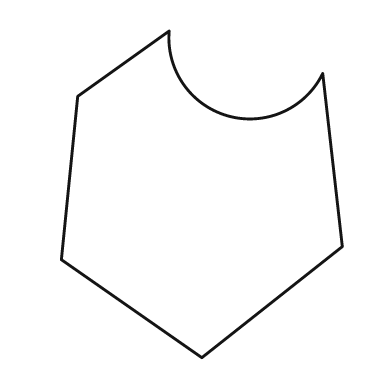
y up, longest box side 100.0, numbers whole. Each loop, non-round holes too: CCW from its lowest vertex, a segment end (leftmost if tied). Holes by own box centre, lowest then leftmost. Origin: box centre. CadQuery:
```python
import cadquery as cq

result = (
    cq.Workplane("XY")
    .moveTo(0.0, -50.0)
    .lineTo(43.0, -16.0)
    .lineTo(37.0, 37.0)
    .threePointArc((8.0, 24.0), (-10.0, 50.0))
    .lineTo(-38.0, 30.0)
    .lineTo(-43.0, -20.0)
    .close()
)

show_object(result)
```